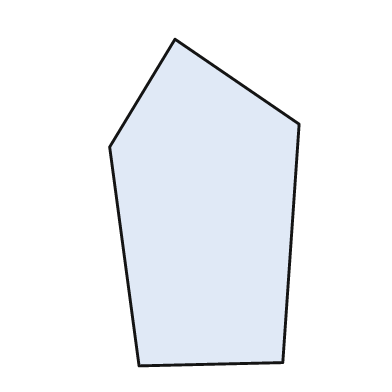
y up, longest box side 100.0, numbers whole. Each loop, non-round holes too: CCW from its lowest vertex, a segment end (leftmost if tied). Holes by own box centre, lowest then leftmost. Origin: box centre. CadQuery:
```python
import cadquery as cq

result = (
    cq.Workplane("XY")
    .moveTo(-20.0, -50.0)
    .lineTo(24.0, -49.0)
    .lineTo(29.0, 24.0)
    .lineTo(-9.0, 50.0)
    .lineTo(-29.0, 17.0)
    .close()
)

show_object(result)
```